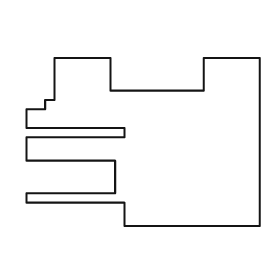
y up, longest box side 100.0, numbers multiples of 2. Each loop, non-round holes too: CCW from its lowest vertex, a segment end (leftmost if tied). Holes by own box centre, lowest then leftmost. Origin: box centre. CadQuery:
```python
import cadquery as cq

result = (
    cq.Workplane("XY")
    .moveTo(-8.0, -36.0)
    .lineTo(50.0, -36.0)
    .lineTo(50.0, 36.0)
    .lineTo(26.0, 36.0)
    .lineTo(26.0, 22.0)
    .lineTo(-14.0, 22.0)
    .lineTo(-14.0, 36.0)
    .lineTo(-38.0, 36.0)
    .lineTo(-38.0, 18.0)
    .lineTo(-42.0, 18.0)
    .lineTo(-42.0, 14.0)
    .lineTo(-50.0, 14.0)
    .lineTo(-50.0, 6.0)
    .lineTo(-8.0, 6.0)
    .lineTo(-8.0, 2.0)
    .lineTo(-50.0, 2.0)
    .lineTo(-50.0, -8.0)
    .lineTo(-12.0, -8.0)
    .lineTo(-12.0, -22.0)
    .lineTo(-50.0, -22.0)
    .lineTo(-50.0, -26.0)
    .lineTo(-8.0, -26.0)
    .close()
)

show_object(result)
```